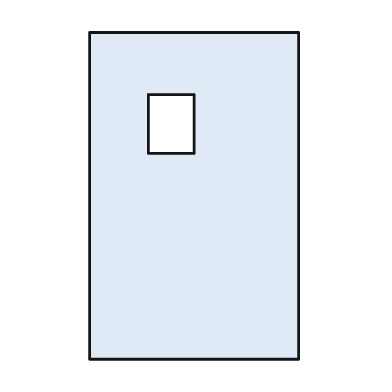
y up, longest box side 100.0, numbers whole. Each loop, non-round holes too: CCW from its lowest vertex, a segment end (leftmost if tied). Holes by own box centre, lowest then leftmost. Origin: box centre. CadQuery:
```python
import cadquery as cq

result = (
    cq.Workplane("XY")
    .moveTo(-32.0, -50.0)
    .lineTo(32.0, -50.0)
    .lineTo(32.0, 50.0)
    .lineTo(-32.0, 50.0)
    .close()
    .moveTo(-14.0, 13.0)
    .lineTo(0.0, 13.0)
    .lineTo(0.0, 31.0)
    .lineTo(-14.0, 31.0)
    .close()
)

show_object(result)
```